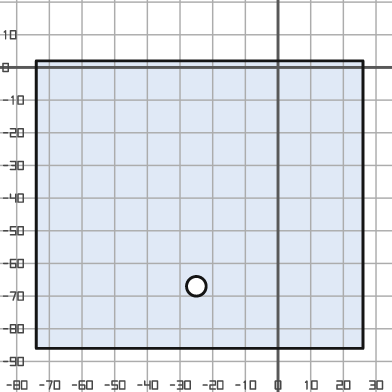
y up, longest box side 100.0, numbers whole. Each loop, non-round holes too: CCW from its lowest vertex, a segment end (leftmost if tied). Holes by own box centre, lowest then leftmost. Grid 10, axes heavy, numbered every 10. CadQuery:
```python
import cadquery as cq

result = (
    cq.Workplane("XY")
    .moveTo(-74.0, -86.0)
    .lineTo(26.0, -86.0)
    .lineTo(26.0, 2.0)
    .lineTo(-74.0, 2.0)
    .close()
    .moveTo(-25.0, -67.0)
    .circle(3.0)
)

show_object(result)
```